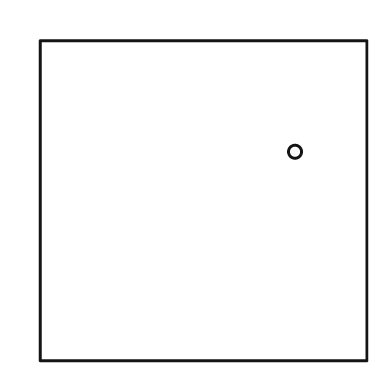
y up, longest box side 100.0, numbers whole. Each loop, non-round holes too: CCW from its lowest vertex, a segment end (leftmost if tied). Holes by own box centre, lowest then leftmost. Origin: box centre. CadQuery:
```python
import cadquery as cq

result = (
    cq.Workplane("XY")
    .moveTo(-50.0, -49.0)
    .lineTo(50.0, -49.0)
    .lineTo(50.0, 49.0)
    .lineTo(-50.0, 49.0)
    .close()
    .moveTo(28.0, 15.0)
    .circle(2.0)
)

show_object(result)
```